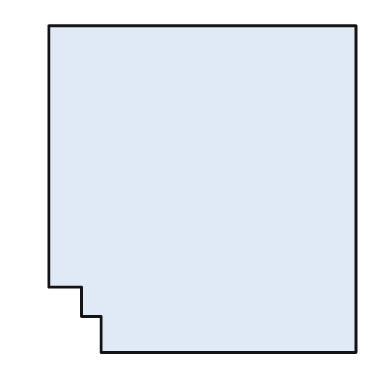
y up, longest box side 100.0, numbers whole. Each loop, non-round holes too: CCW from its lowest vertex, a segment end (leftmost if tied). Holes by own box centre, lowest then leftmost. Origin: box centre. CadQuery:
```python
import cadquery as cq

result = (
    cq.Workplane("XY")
    .moveTo(-31.0, -50.0)
    .lineTo(47.0, -50.0)
    .lineTo(47.0, 50.0)
    .lineTo(-47.0, 50.0)
    .lineTo(-47.0, -30.0)
    .lineTo(-37.0, -30.0)
    .lineTo(-37.0, -39.0)
    .lineTo(-31.0, -39.0)
    .close()
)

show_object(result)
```